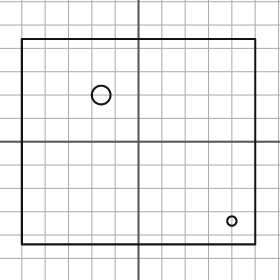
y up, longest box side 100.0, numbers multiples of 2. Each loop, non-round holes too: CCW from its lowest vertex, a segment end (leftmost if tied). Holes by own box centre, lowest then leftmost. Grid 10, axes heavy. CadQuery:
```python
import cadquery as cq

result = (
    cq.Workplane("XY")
    .moveTo(-50.0, -44.0)
    .lineTo(50.0, -44.0)
    .lineTo(50.0, 44.0)
    .lineTo(-50.0, 44.0)
    .close()
    .moveTo(40.0, -34.0)
    .circle(2.0)
    .moveTo(-16.0, 20.0)
    .circle(4.0)
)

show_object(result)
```